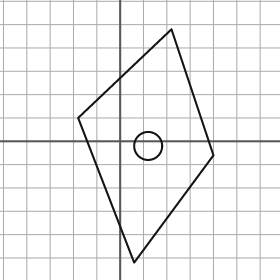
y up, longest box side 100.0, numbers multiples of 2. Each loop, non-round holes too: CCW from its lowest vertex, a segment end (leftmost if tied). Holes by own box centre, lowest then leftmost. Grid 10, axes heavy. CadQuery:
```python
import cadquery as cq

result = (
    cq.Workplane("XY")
    .moveTo(6.0, -52.0)
    .lineTo(40.0, -6.0)
    .lineTo(22.0, 48.0)
    .lineTo(-18.0, 10.0)
    .close()
    .moveTo(12.0, -2.0)
    .circle(6.0)
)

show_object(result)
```